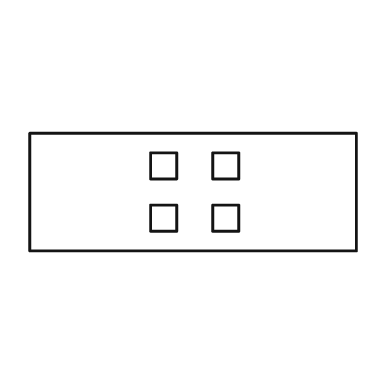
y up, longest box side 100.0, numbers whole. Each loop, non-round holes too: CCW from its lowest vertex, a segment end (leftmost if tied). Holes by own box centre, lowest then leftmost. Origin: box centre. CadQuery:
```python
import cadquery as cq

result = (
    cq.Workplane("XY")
    .moveTo(-50.0, -18.0)
    .lineTo(50.0, -18.0)
    .lineTo(50.0, 18.0)
    .lineTo(-50.0, 18.0)
    .close()
    .moveTo(-13.0, -12.0)
    .lineTo(-5.0, -12.0)
    .lineTo(-5.0, -4.0)
    .lineTo(-13.0, -4.0)
    .close()
    .moveTo(6.0, -12.0)
    .lineTo(14.0, -12.0)
    .lineTo(14.0, -4.0)
    .lineTo(6.0, -4.0)
    .close()
    .moveTo(-13.0, 4.0)
    .lineTo(-5.0, 4.0)
    .lineTo(-5.0, 12.0)
    .lineTo(-13.0, 12.0)
    .close()
    .moveTo(6.0, 4.0)
    .lineTo(14.0, 4.0)
    .lineTo(14.0, 12.0)
    .lineTo(6.0, 12.0)
    .close()
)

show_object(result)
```